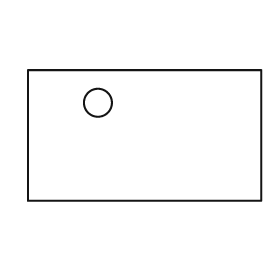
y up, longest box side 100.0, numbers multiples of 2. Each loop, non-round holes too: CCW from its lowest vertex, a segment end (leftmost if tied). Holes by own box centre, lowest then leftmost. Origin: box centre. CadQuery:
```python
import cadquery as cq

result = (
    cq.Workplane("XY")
    .moveTo(-50.0, -28.0)
    .lineTo(50.0, -28.0)
    .lineTo(50.0, 28.0)
    .lineTo(-50.0, 28.0)
    .close()
    .moveTo(-20.0, 14.0)
    .circle(6.0)
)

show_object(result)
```